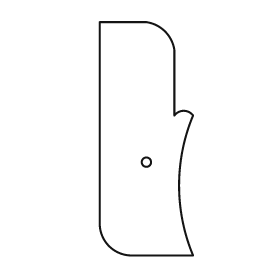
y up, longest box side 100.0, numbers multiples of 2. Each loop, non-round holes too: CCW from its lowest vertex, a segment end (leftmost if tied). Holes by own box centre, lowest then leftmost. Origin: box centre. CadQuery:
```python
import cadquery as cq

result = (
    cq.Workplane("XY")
    .moveTo(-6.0, -50.0)
    .lineTo(20.0, -50.0)
    .threePointArc((14.0, -20.0), (20.0, 10.0))
    .threePointArc((16.0, 12.0), (12.0, 10.0))
    .lineTo(12.0, 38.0)
    .threePointArc((8.0, 46.0), (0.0, 50.0))
    .lineTo(-20.0, 50.0)
    .lineTo(-20.0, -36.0)
    .threePointArc((-16.0, -46.0), (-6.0, -50.0))
    .close()
    .moveTo(0.0, -10.0)
    .circle(2.0)
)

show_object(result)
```